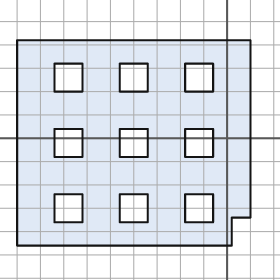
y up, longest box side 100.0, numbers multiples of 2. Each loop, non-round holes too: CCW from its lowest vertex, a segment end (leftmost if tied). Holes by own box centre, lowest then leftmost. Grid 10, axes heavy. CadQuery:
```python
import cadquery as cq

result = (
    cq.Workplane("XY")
    .moveTo(-90.0, -46.0)
    .lineTo(2.0, -46.0)
    .lineTo(2.0, -34.0)
    .lineTo(10.0, -34.0)
    .lineTo(10.0, 42.0)
    .lineTo(-90.0, 42.0)
    .close()
    .moveTo(-74.0, -36.0)
    .lineTo(-62.0, -36.0)
    .lineTo(-62.0, -24.0)
    .lineTo(-74.0, -24.0)
    .close()
    .moveTo(-46.0, -36.0)
    .lineTo(-34.0, -36.0)
    .lineTo(-34.0, -24.0)
    .lineTo(-46.0, -24.0)
    .close()
    .moveTo(-18.0, -36.0)
    .lineTo(-6.0, -36.0)
    .lineTo(-6.0, -24.0)
    .lineTo(-18.0, -24.0)
    .close()
    .moveTo(-74.0, -8.0)
    .lineTo(-62.0, -8.0)
    .lineTo(-62.0, 4.0)
    .lineTo(-74.0, 4.0)
    .close()
    .moveTo(-46.0, -8.0)
    .lineTo(-34.0, -8.0)
    .lineTo(-34.0, 4.0)
    .lineTo(-46.0, 4.0)
    .close()
    .moveTo(-18.0, -8.0)
    .lineTo(-6.0, -8.0)
    .lineTo(-6.0, 4.0)
    .lineTo(-18.0, 4.0)
    .close()
    .moveTo(-74.0, 20.0)
    .lineTo(-62.0, 20.0)
    .lineTo(-62.0, 32.0)
    .lineTo(-74.0, 32.0)
    .close()
    .moveTo(-46.0, 20.0)
    .lineTo(-34.0, 20.0)
    .lineTo(-34.0, 32.0)
    .lineTo(-46.0, 32.0)
    .close()
    .moveTo(-18.0, 20.0)
    .lineTo(-6.0, 20.0)
    .lineTo(-6.0, 32.0)
    .lineTo(-18.0, 32.0)
    .close()
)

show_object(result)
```